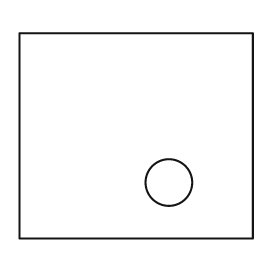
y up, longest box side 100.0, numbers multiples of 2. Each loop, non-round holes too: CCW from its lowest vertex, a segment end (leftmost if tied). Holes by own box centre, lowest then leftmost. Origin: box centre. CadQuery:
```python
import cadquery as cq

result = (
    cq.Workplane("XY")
    .moveTo(-50.0, -44.0)
    .lineTo(50.0, -44.0)
    .lineTo(50.0, 44.0)
    .lineTo(-50.0, 44.0)
    .close()
    .moveTo(14.0, -20.0)
    .circle(10.0)
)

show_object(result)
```